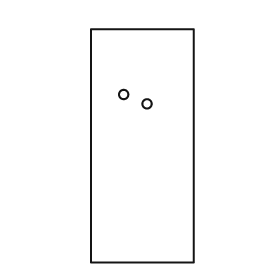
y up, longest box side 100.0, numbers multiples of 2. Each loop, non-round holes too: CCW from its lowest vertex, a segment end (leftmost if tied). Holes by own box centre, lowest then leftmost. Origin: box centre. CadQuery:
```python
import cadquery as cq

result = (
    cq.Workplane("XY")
    .moveTo(-22.0, -50.0)
    .lineTo(22.0, -50.0)
    .lineTo(22.0, 50.0)
    .lineTo(-22.0, 50.0)
    .close()
    .moveTo(2.0, 18.0)
    .circle(2.0)
    .moveTo(-8.0, 22.0)
    .circle(2.0)
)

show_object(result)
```